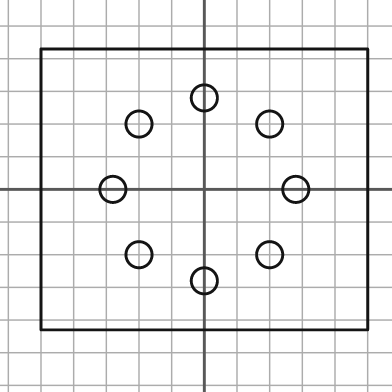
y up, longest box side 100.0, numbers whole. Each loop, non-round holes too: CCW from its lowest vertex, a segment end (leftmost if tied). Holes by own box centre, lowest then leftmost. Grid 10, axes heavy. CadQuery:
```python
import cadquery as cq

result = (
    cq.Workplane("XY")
    .moveTo(-50.0, -43.0)
    .lineTo(50.0, -43.0)
    .lineTo(50.0, 43.0)
    .lineTo(-50.0, 43.0)
    .close()
    .moveTo(0.0, -28.0)
    .circle(4.0)
    .moveTo(-20.0, -20.0)
    .circle(4.0)
    .moveTo(20.0, -20.0)
    .circle(4.0)
    .moveTo(-28.0, 0.0)
    .circle(4.0)
    .moveTo(28.0, 0.0)
    .circle(4.0)
    .moveTo(-20.0, 20.0)
    .circle(4.0)
    .moveTo(20.0, 20.0)
    .circle(4.0)
    .moveTo(0.0, 28.0)
    .circle(4.0)
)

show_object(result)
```